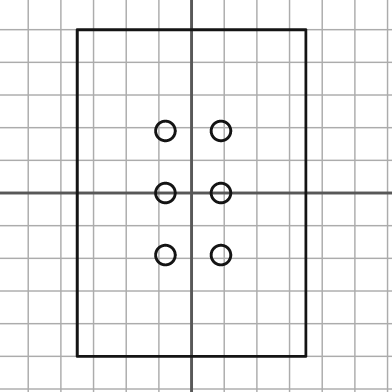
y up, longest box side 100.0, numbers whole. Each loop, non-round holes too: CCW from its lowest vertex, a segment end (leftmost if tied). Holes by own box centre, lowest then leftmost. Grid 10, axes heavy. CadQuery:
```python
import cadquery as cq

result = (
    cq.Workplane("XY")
    .moveTo(-35.0, -50.0)
    .lineTo(35.0, -50.0)
    .lineTo(35.0, 50.0)
    .lineTo(-35.0, 50.0)
    .close()
    .moveTo(-8.0, -19.0)
    .circle(3.0)
    .moveTo(9.0, -19.0)
    .circle(3.0)
    .moveTo(-8.0, 0.0)
    .circle(3.0)
    .moveTo(9.0, 0.0)
    .circle(3.0)
    .moveTo(-8.0, 19.0)
    .circle(3.0)
    .moveTo(9.0, 19.0)
    .circle(3.0)
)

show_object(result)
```